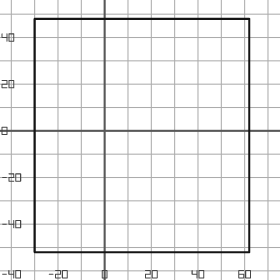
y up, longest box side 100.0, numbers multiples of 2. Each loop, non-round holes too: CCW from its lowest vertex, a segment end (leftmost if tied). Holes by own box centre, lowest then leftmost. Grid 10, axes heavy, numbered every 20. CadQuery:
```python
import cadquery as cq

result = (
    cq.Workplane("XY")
    .moveTo(-30.0, -52.0)
    .lineTo(62.0, -52.0)
    .lineTo(62.0, 48.0)
    .lineTo(-30.0, 48.0)
    .close()
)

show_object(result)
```